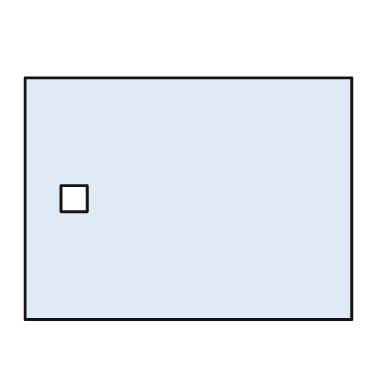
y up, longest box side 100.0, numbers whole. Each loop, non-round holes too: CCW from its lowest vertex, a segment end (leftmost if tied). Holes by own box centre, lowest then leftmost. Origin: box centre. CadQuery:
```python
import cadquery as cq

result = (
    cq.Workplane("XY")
    .moveTo(-50.0, -37.0)
    .lineTo(50.0, -37.0)
    .lineTo(50.0, 37.0)
    .lineTo(-50.0, 37.0)
    .close()
    .moveTo(-39.0, -4.0)
    .lineTo(-31.0, -4.0)
    .lineTo(-31.0, 4.0)
    .lineTo(-39.0, 4.0)
    .close()
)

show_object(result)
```